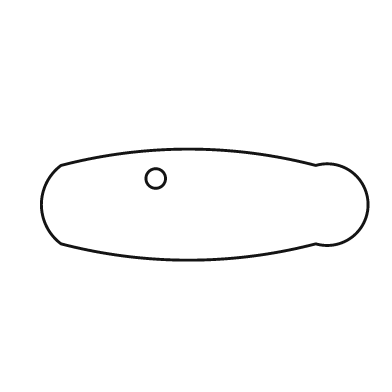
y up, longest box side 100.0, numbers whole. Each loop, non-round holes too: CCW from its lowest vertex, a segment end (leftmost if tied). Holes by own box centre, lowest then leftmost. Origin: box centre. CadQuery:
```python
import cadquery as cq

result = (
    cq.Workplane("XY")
    .moveTo(-44.0, -12.0)
    .threePointArc((-5.0, -17.0), (34.0, -12.0))
    .threePointArc((50.0, 0.0), (34.0, 12.0))
    .threePointArc((-5.0, 17.0), (-44.0, 12.0))
    .threePointArc((-50.0, 0.0), (-44.0, -12.0))
    .close()
    .moveTo(-15.0, 8.0)
    .circle(3.0)
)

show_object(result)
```